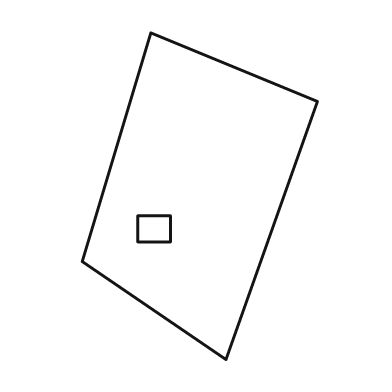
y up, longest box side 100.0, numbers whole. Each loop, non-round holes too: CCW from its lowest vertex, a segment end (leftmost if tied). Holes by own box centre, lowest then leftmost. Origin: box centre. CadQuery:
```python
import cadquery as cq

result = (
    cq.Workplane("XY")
    .moveTo(8.0, -50.0)
    .lineTo(36.0, 29.0)
    .lineTo(-15.0, 50.0)
    .lineTo(-36.0, -20.0)
    .close()
    .moveTo(-19.0, -14.0)
    .lineTo(-9.0, -14.0)
    .lineTo(-9.0, -6.0)
    .lineTo(-19.0, -6.0)
    .close()
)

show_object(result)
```